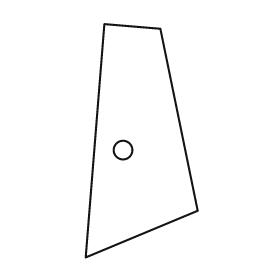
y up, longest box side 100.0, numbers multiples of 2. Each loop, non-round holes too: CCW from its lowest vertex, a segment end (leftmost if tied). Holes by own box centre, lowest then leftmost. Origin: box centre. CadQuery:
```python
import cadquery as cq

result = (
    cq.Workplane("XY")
    .moveTo(-24.0, -50.0)
    .lineTo(24.0, -30.0)
    .lineTo(8.0, 48.0)
    .lineTo(-16.0, 50.0)
    .close()
    .moveTo(-8.0, -4.0)
    .circle(4.0)
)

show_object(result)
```